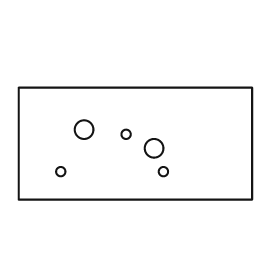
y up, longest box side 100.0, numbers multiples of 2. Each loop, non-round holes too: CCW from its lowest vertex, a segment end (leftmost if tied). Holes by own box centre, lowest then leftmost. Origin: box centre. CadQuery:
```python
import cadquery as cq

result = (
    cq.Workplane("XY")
    .moveTo(-50.0, -24.0)
    .lineTo(50.0, -24.0)
    .lineTo(50.0, 24.0)
    .lineTo(-50.0, 24.0)
    .close()
    .moveTo(-32.0, -12.0)
    .circle(2.0)
    .moveTo(12.0, -12.0)
    .circle(2.0)
    .moveTo(8.0, -2.0)
    .circle(4.0)
    .moveTo(-4.0, 4.0)
    .circle(2.0)
    .moveTo(-22.0, 6.0)
    .circle(4.0)
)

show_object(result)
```